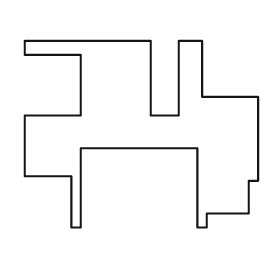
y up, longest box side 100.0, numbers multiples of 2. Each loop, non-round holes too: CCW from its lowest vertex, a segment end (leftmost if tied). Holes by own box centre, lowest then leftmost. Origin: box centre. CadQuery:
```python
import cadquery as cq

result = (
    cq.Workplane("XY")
    .moveTo(-30.0, -40.0)
    .lineTo(-26.0, -40.0)
    .lineTo(-26.0, -6.0)
    .lineTo(24.0, -6.0)
    .lineTo(24.0, -40.0)
    .lineTo(28.0, -40.0)
    .lineTo(28.0, -34.0)
    .lineTo(46.0, -34.0)
    .lineTo(46.0, -20.0)
    .lineTo(50.0, -20.0)
    .lineTo(50.0, 16.0)
    .lineTo(26.0, 16.0)
    .lineTo(26.0, 40.0)
    .lineTo(16.0, 40.0)
    .lineTo(16.0, 8.0)
    .lineTo(4.0, 8.0)
    .lineTo(4.0, 40.0)
    .lineTo(-50.0, 40.0)
    .lineTo(-50.0, 34.0)
    .lineTo(-26.0, 34.0)
    .lineTo(-26.0, 8.0)
    .lineTo(-50.0, 8.0)
    .lineTo(-50.0, -18.0)
    .lineTo(-30.0, -18.0)
    .close()
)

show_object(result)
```